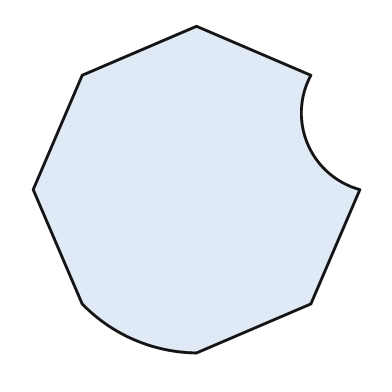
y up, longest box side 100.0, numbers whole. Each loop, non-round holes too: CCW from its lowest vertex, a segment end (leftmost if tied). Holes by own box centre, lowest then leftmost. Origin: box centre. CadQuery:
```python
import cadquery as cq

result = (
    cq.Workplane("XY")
    .moveTo(0.0, -50.0)
    .lineTo(35.0, -35.0)
    .lineTo(50.0, 0.0)
    .threePointArc((34.0, 14.0), (35.0, 35.0))
    .lineTo(0.0, 50.0)
    .lineTo(-35.0, 35.0)
    .lineTo(-50.0, 0.0)
    .lineTo(-35.0, -35.0)
    .threePointArc((-19.0, -46.0), (0.0, -50.0))
    .close()
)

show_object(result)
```